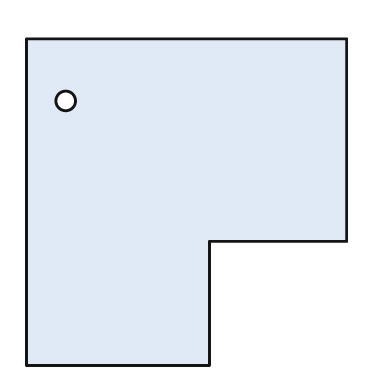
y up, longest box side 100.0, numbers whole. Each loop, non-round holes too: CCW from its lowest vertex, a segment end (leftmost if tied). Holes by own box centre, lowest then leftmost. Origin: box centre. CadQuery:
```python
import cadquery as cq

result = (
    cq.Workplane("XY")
    .moveTo(-49.0, -50.0)
    .lineTo(7.0, -50.0)
    .lineTo(7.0, -12.0)
    .lineTo(49.0, -12.0)
    .lineTo(49.0, 50.0)
    .lineTo(-49.0, 50.0)
    .close()
    .moveTo(-37.0, 31.0)
    .circle(3.0)
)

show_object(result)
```